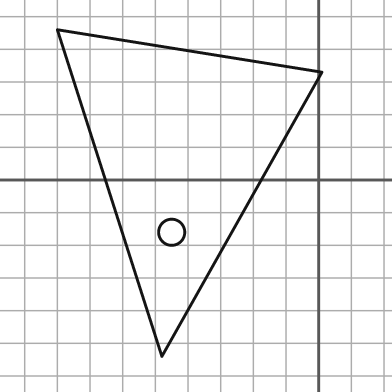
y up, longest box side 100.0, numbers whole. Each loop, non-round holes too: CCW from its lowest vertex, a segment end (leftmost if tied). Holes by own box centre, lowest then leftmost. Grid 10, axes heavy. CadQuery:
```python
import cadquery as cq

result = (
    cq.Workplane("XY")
    .moveTo(-48.0, -54.0)
    .lineTo(1.0, 33.0)
    .lineTo(-80.0, 46.0)
    .close()
    .moveTo(-45.0, -16.0)
    .circle(4.0)
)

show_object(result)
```